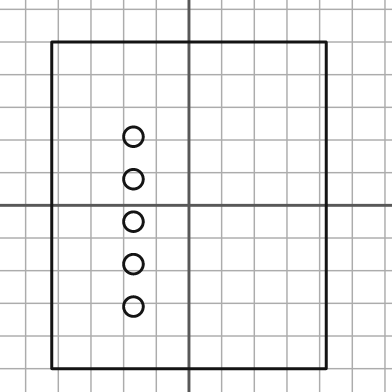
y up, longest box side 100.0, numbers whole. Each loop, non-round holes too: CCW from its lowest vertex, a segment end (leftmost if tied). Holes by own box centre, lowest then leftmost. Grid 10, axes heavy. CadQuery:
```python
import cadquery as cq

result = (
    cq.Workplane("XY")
    .moveTo(-42.0, -50.0)
    .lineTo(42.0, -50.0)
    .lineTo(42.0, 50.0)
    .lineTo(-42.0, 50.0)
    .close()
    .moveTo(-17.0, -31.0)
    .circle(3.0)
    .moveTo(-17.0, -18.0)
    .circle(3.0)
    .moveTo(-17.0, -5.0)
    .circle(3.0)
    .moveTo(-17.0, 8.0)
    .circle(3.0)
    .moveTo(-17.0, 21.0)
    .circle(3.0)
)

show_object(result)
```